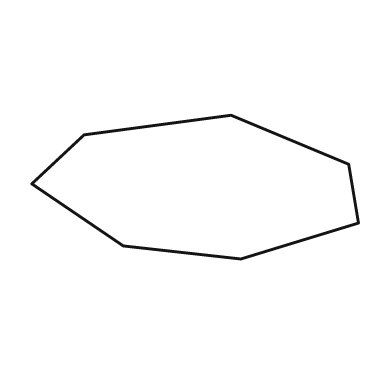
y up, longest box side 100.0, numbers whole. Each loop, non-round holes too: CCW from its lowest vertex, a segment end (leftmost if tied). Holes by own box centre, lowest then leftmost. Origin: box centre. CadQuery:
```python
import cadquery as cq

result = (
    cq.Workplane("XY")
    .moveTo(14.0, -22.0)
    .lineTo(50.0, -11.0)
    .lineTo(47.0, 7.0)
    .lineTo(11.0, 22.0)
    .lineTo(-34.0, 16.0)
    .lineTo(-50.0, 1.0)
    .lineTo(-22.0, -18.0)
    .close()
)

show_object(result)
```